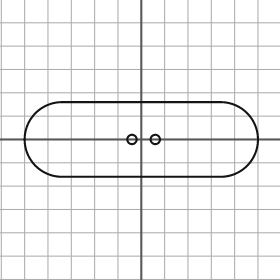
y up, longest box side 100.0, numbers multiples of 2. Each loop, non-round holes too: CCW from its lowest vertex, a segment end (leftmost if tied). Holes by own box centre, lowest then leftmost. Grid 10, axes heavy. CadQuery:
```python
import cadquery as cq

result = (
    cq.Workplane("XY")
    .moveTo(-34.0, -16.0)
    .lineTo(34.0, -16.0)
    .threePointArc((50.0, 0.0), (34.0, 16.0))
    .lineTo(-34.0, 16.0)
    .threePointArc((-50.0, 0.0), (-34.0, -16.0))
    .close()
    .moveTo(-4.0, 0.0)
    .circle(2.0)
    .moveTo(6.0, 0.0)
    .circle(2.0)
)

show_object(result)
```